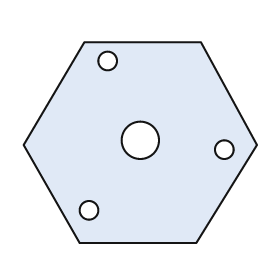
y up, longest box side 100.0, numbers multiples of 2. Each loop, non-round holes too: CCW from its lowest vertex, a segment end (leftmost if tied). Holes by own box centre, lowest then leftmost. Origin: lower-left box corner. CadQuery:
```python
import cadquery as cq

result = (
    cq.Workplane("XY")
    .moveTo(24.0, 0.0)
    .lineTo(74.0, 0.0)
    .lineTo(100.0, 42.0)
    .lineTo(76.0, 86.0)
    .lineTo(26.0, 86.0)
    .lineTo(0.0, 42.0)
    .close()
    .moveTo(28.0, 14.0)
    .circle(4.0)
    .moveTo(86.0, 40.0)
    .circle(4.0)
    .moveTo(50.0, 44.0)
    .circle(8.0)
    .moveTo(36.0, 78.0)
    .circle(4.0)
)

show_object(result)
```